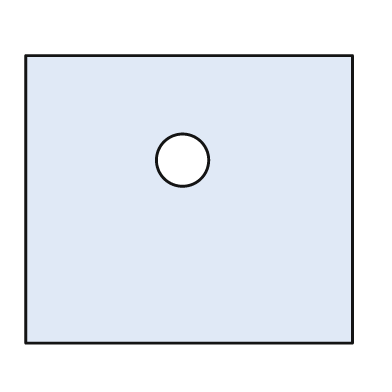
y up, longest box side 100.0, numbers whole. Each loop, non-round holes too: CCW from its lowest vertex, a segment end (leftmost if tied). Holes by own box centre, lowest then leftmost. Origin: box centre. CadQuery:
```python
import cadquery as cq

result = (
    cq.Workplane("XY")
    .moveTo(-50.0, -44.0)
    .lineTo(50.0, -44.0)
    .lineTo(50.0, 44.0)
    .lineTo(-50.0, 44.0)
    .close()
    .moveTo(-2.0, 12.0)
    .circle(8.0)
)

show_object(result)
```